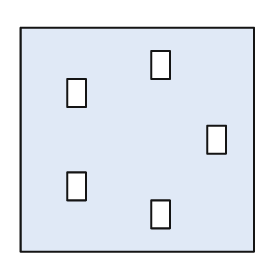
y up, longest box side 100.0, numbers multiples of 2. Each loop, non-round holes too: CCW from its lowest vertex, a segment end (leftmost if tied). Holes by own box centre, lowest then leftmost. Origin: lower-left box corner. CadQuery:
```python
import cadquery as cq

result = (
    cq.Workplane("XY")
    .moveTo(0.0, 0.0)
    .lineTo(100.0, 0.0)
    .lineTo(100.0, 96.0)
    .lineTo(0.0, 96.0)
    .close()
    .moveTo(56.0, 10.0)
    .lineTo(64.0, 10.0)
    .lineTo(64.0, 22.0)
    .lineTo(56.0, 22.0)
    .close()
    .moveTo(20.0, 22.0)
    .lineTo(28.0, 22.0)
    .lineTo(28.0, 34.0)
    .lineTo(20.0, 34.0)
    .close()
    .moveTo(80.0, 42.0)
    .lineTo(88.0, 42.0)
    .lineTo(88.0, 54.0)
    .lineTo(80.0, 54.0)
    .close()
    .moveTo(20.0, 62.0)
    .lineTo(28.0, 62.0)
    .lineTo(28.0, 74.0)
    .lineTo(20.0, 74.0)
    .close()
    .moveTo(56.0, 74.0)
    .lineTo(64.0, 74.0)
    .lineTo(64.0, 86.0)
    .lineTo(56.0, 86.0)
    .close()
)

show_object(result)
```